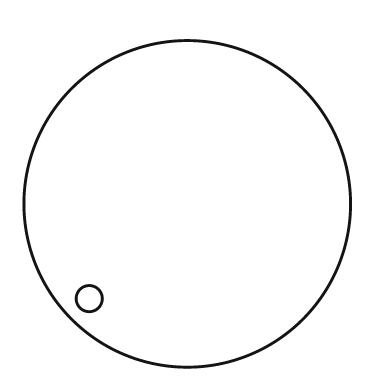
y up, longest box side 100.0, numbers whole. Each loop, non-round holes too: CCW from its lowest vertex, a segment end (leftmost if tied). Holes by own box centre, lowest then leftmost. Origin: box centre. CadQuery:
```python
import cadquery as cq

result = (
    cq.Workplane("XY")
    .moveTo(0.0, 0.0)
    .circle(50.0)
    .moveTo(-30.0, -29.0)
    .circle(4.0)
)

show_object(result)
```